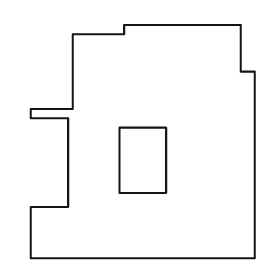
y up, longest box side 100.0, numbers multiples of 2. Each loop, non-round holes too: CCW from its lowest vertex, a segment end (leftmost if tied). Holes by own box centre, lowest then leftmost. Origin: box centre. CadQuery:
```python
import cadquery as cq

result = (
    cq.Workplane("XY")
    .moveTo(-48.0, -50.0)
    .lineTo(48.0, -50.0)
    .lineTo(48.0, 30.0)
    .lineTo(42.0, 30.0)
    .lineTo(42.0, 50.0)
    .lineTo(-8.0, 50.0)
    .lineTo(-8.0, 46.0)
    .lineTo(-30.0, 46.0)
    .lineTo(-30.0, 14.0)
    .lineTo(-48.0, 14.0)
    .lineTo(-48.0, 10.0)
    .lineTo(-32.0, 10.0)
    .lineTo(-32.0, -28.0)
    .lineTo(-48.0, -28.0)
    .close()
    .moveTo(-10.0, -22.0)
    .lineTo(10.0, -22.0)
    .lineTo(10.0, 6.0)
    .lineTo(-10.0, 6.0)
    .close()
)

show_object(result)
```